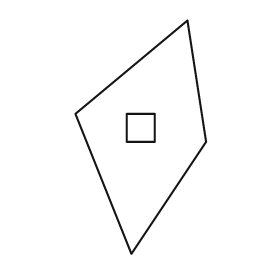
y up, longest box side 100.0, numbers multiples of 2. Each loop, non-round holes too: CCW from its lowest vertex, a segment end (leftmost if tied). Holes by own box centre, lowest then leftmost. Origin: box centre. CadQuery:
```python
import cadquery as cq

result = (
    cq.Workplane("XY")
    .moveTo(-4.0, -50.0)
    .lineTo(28.0, -2.0)
    .lineTo(20.0, 50.0)
    .lineTo(-28.0, 10.0)
    .close()
    .moveTo(-6.0, -2.0)
    .lineTo(6.0, -2.0)
    .lineTo(6.0, 10.0)
    .lineTo(-6.0, 10.0)
    .close()
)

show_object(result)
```